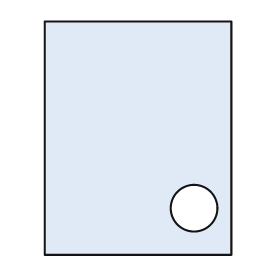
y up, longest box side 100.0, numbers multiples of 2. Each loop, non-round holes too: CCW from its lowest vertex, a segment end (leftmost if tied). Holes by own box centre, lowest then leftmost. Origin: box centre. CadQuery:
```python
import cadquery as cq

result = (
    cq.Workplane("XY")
    .moveTo(-40.0, -50.0)
    .lineTo(40.0, -50.0)
    .lineTo(40.0, 50.0)
    .lineTo(-40.0, 50.0)
    .close()
    .moveTo(24.0, -30.0)
    .circle(10.0)
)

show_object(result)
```